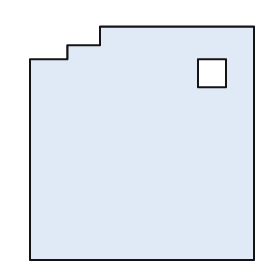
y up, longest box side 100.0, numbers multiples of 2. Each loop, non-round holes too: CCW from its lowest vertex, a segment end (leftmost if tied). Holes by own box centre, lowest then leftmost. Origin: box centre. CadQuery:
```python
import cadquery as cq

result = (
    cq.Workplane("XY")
    .moveTo(-48.0, -50.0)
    .lineTo(48.0, -50.0)
    .lineTo(48.0, 50.0)
    .lineTo(-18.0, 50.0)
    .lineTo(-18.0, 42.0)
    .lineTo(-32.0, 42.0)
    .lineTo(-32.0, 36.0)
    .lineTo(-48.0, 36.0)
    .close()
    .moveTo(24.0, 24.0)
    .lineTo(36.0, 24.0)
    .lineTo(36.0, 36.0)
    .lineTo(24.0, 36.0)
    .close()
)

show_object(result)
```